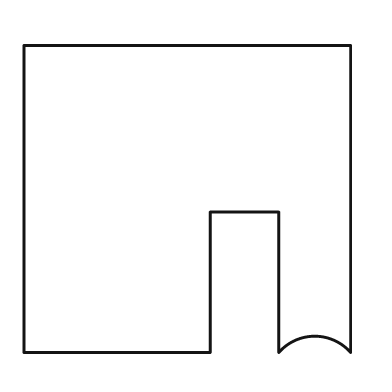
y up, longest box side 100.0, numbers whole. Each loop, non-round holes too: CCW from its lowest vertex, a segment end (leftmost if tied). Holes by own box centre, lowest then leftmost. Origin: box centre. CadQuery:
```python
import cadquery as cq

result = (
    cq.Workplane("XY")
    .moveTo(-50.0, -47.0)
    .lineTo(7.0, -47.0)
    .lineTo(7.0, -4.0)
    .lineTo(28.0, -4.0)
    .lineTo(28.0, -47.0)
    .threePointArc((39.0, -42.0), (50.0, -47.0))
    .lineTo(50.0, 47.0)
    .lineTo(-50.0, 47.0)
    .close()
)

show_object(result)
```